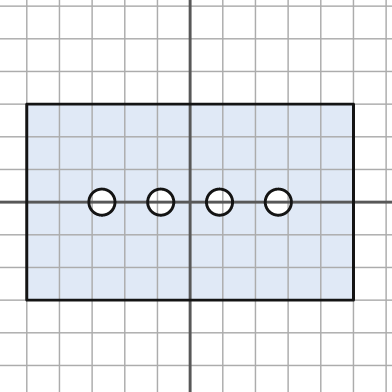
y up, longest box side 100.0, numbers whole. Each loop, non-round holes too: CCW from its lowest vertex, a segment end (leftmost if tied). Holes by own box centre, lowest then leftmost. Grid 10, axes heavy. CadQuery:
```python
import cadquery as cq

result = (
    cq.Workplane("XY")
    .moveTo(-50.0, -30.0)
    .lineTo(50.0, -30.0)
    .lineTo(50.0, 30.0)
    .lineTo(-50.0, 30.0)
    .close()
    .moveTo(-27.0, 0.0)
    .circle(4.0)
    .moveTo(-9.0, 0.0)
    .circle(4.0)
    .moveTo(9.0, 0.0)
    .circle(4.0)
    .moveTo(27.0, 0.0)
    .circle(4.0)
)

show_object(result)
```